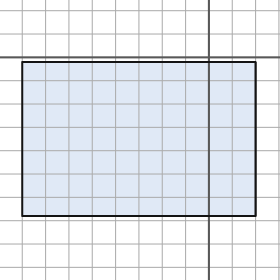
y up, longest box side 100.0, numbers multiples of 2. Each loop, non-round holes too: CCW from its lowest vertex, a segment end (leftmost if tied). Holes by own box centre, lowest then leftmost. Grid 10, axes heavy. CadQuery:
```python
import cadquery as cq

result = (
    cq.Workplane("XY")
    .moveTo(-80.0, -68.0)
    .lineTo(20.0, -68.0)
    .lineTo(20.0, -2.0)
    .lineTo(-80.0, -2.0)
    .close()
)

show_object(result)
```